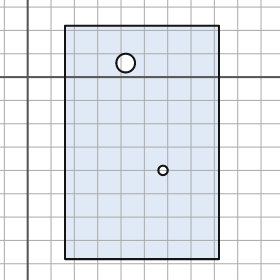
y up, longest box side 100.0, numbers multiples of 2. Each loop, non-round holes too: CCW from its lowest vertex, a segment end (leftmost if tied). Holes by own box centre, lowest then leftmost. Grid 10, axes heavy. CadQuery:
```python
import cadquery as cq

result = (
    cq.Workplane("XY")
    .moveTo(16.0, -78.0)
    .lineTo(82.0, -78.0)
    .lineTo(82.0, 22.0)
    .lineTo(16.0, 22.0)
    .close()
    .moveTo(58.0, -40.0)
    .circle(2.0)
    .moveTo(42.0, 6.0)
    .circle(4.0)
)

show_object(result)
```